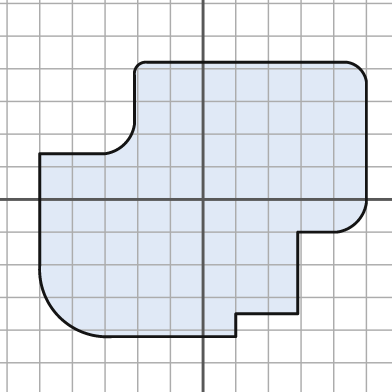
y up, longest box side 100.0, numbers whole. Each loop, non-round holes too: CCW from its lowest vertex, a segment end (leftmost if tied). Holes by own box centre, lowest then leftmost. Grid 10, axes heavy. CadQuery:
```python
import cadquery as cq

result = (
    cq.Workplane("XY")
    .moveTo(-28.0, -42.0)
    .lineTo(10.0, -42.0)
    .lineTo(10.0, -35.0)
    .lineTo(29.0, -35.0)
    .lineTo(29.0, -10.0)
    .lineTo(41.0, -10.0)
    .threePointArc((47.0, -7.0), (50.0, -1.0))
    .lineTo(50.0, 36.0)
    .threePointArc((48.0, 40.0), (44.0, 42.0))
    .lineTo(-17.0, 42.0)
    .threePointArc((-20.0, 41.0), (-21.0, 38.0))
    .lineTo(-21.0, 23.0)
    .threePointArc((-24.0, 17.0), (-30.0, 14.0))
    .lineTo(-50.0, 14.0)
    .lineTo(-50.0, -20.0)
    .threePointArc((-44.0, -36.0), (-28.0, -42.0))
    .close()
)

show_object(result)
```